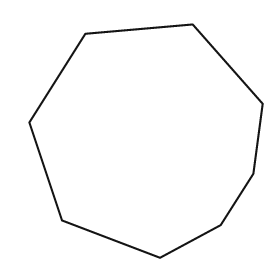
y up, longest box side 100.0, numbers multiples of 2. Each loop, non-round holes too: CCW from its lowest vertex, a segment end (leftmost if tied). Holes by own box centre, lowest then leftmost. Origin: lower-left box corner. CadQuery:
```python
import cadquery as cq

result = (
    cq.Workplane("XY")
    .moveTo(56.0, 0.0)
    .lineTo(82.0, 14.0)
    .lineTo(96.0, 36.0)
    .lineTo(100.0, 66.0)
    .lineTo(70.0, 100.0)
    .lineTo(24.0, 96.0)
    .lineTo(0.0, 58.0)
    .lineTo(14.0, 16.0)
    .close()
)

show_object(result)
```